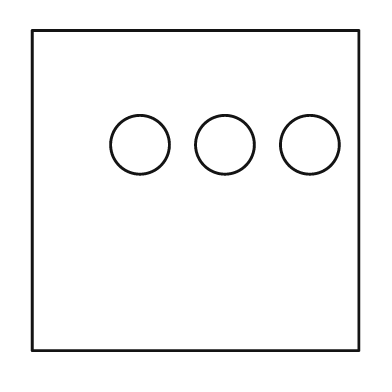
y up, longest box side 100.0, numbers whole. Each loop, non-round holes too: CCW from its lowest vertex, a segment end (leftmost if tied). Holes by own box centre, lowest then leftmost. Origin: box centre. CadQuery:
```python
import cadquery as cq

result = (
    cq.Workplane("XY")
    .moveTo(-50.0, -49.0)
    .lineTo(50.0, -49.0)
    .lineTo(50.0, 49.0)
    .lineTo(-50.0, 49.0)
    .close()
    .moveTo(-17.0, 14.0)
    .circle(9.0)
    .moveTo(9.0, 14.0)
    .circle(9.0)
    .moveTo(35.0, 14.0)
    .circle(9.0)
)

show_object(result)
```